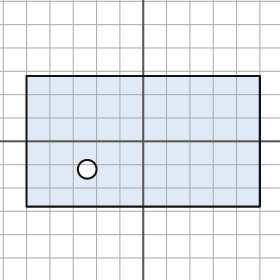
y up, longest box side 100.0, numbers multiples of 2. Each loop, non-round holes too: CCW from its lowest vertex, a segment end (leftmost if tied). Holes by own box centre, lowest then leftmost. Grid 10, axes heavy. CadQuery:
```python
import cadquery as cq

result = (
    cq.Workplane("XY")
    .moveTo(-50.0, -28.0)
    .lineTo(50.0, -28.0)
    .lineTo(50.0, 28.0)
    .lineTo(-50.0, 28.0)
    .close()
    .moveTo(-24.0, -12.0)
    .circle(4.0)
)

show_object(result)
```